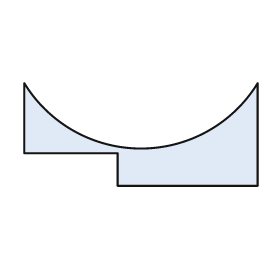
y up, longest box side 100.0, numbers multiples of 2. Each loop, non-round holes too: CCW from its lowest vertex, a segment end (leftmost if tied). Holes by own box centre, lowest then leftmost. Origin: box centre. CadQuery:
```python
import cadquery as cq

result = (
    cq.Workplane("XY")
    .moveTo(-10.0, -22.0)
    .lineTo(50.0, -22.0)
    .lineTo(50.0, 22.0)
    .threePointArc((0.0, -6.0), (-50.0, 22.0))
    .lineTo(-50.0, -8.0)
    .lineTo(-10.0, -8.0)
    .close()
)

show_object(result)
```